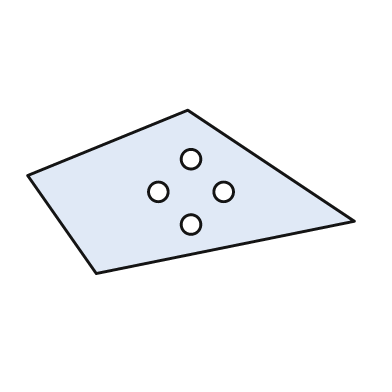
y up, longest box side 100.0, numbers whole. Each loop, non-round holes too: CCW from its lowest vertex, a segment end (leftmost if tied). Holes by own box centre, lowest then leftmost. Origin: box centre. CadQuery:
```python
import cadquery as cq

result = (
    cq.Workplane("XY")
    .moveTo(-29.0, -25.0)
    .lineTo(50.0, -9.0)
    .lineTo(-1.0, 25.0)
    .lineTo(-50.0, 5.0)
    .close()
    .moveTo(0.0, -10.0)
    .circle(3.0)
    .moveTo(-10.0, 0.0)
    .circle(3.0)
    .moveTo(10.0, 0.0)
    .circle(3.0)
    .moveTo(0.0, 10.0)
    .circle(3.0)
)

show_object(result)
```